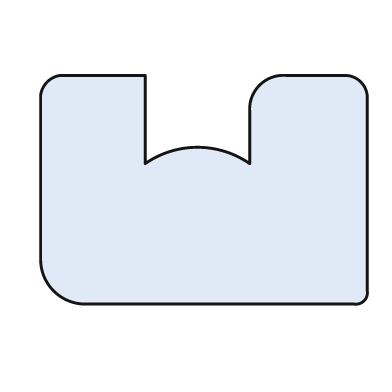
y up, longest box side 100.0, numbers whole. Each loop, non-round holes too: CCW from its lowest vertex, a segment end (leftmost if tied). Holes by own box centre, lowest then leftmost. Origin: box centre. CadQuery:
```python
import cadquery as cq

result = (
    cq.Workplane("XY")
    .moveTo(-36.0, -35.0)
    .lineTo(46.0, -35.0)
    .threePointArc((49.0, -34.0), (50.0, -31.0))
    .lineTo(50.0, 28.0)
    .threePointArc((48.0, 33.0), (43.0, 35.0))
    .lineTo(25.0, 35.0)
    .threePointArc((17.0, 32.0), (14.0, 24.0))
    .lineTo(14.0, 8.0)
    .threePointArc((-2.0, 13.0), (-18.0, 8.0))
    .lineTo(-18.0, 35.0)
    .lineTo(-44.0, 35.0)
    .threePointArc((-48.0, 33.0), (-50.0, 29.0))
    .lineTo(-50.0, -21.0)
    .threePointArc((-46.0, -31.0), (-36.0, -35.0))
    .close()
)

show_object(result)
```